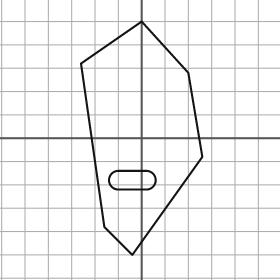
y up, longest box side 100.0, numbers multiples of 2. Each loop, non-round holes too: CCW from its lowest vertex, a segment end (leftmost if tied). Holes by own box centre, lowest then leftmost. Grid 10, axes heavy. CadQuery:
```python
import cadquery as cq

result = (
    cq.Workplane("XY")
    .moveTo(-4.0, -50.0)
    .lineTo(26.0, -8.0)
    .lineTo(20.0, 28.0)
    .lineTo(0.0, 50.0)
    .lineTo(-26.0, 32.0)
    .lineTo(-16.0, -38.0)
    .close()
    .moveTo(-10.0, -22.0)
    .lineTo(2.0, -22.0)
    .threePointArc((6.0, -18.0), (2.0, -14.0))
    .lineTo(-10.0, -14.0)
    .threePointArc((-14.0, -18.0), (-10.0, -22.0))
    .close()
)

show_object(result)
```